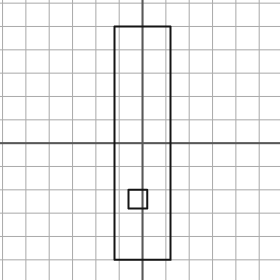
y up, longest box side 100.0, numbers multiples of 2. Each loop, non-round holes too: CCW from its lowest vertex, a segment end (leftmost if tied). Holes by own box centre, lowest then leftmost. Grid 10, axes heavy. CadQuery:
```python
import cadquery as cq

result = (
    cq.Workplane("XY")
    .moveTo(-12.0, -50.0)
    .lineTo(12.0, -50.0)
    .lineTo(12.0, 50.0)
    .lineTo(-12.0, 50.0)
    .close()
    .moveTo(-6.0, -28.0)
    .lineTo(2.0, -28.0)
    .lineTo(2.0, -20.0)
    .lineTo(-6.0, -20.0)
    .close()
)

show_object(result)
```